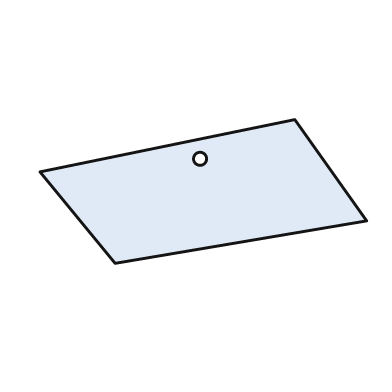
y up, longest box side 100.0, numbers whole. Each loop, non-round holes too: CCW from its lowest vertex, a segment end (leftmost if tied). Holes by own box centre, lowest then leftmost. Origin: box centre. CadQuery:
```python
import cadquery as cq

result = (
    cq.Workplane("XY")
    .moveTo(-27.0, -22.0)
    .lineTo(50.0, -9.0)
    .lineTo(28.0, 22.0)
    .lineTo(-50.0, 6.0)
    .close()
    .moveTo(-1.0, 10.0)
    .circle(2.0)
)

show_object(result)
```